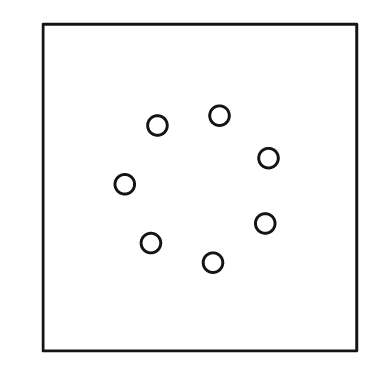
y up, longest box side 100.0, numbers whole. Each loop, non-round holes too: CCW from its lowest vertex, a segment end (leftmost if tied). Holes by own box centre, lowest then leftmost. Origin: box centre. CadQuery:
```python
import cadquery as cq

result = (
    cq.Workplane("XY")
    .moveTo(-48.0, -50.0)
    .lineTo(48.0, -50.0)
    .lineTo(48.0, 50.0)
    .lineTo(-48.0, 50.0)
    .close()
    .moveTo(4.0, -23.0)
    .circle(3.0)
    .moveTo(-15.0, -17.0)
    .circle(3.0)
    .moveTo(20.0, -11.0)
    .circle(3.0)
    .moveTo(-23.0, 1.0)
    .circle(3.0)
    .moveTo(21.0, 9.0)
    .circle(3.0)
    .moveTo(-13.0, 19.0)
    .circle(3.0)
    .moveTo(6.0, 22.0)
    .circle(3.0)
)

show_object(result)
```